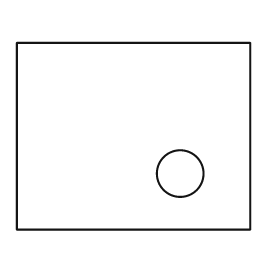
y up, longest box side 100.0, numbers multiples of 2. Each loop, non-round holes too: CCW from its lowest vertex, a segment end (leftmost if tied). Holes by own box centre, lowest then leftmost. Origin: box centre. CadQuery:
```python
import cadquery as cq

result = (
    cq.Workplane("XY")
    .moveTo(-50.0, -40.0)
    .lineTo(50.0, -40.0)
    .lineTo(50.0, 40.0)
    .lineTo(-50.0, 40.0)
    .close()
    .moveTo(20.0, -16.0)
    .circle(10.0)
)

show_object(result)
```